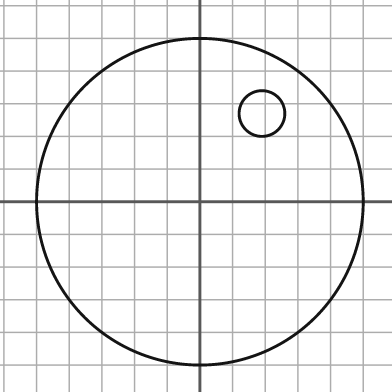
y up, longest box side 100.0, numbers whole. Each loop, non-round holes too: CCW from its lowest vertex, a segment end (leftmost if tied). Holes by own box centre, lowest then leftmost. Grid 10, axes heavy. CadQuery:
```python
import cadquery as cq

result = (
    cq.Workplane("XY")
    .moveTo(0.0, 0.0)
    .circle(50.0)
    .moveTo(19.0, 27.0)
    .circle(7.0)
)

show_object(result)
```